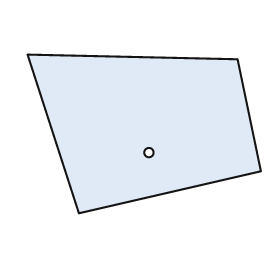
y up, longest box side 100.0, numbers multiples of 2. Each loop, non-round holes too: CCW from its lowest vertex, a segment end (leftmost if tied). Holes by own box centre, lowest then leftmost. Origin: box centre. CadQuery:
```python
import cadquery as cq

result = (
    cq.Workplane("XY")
    .moveTo(-28.0, -34.0)
    .lineTo(50.0, -16.0)
    .lineTo(40.0, 32.0)
    .lineTo(-50.0, 34.0)
    .close()
    .moveTo(2.0, -8.0)
    .circle(2.0)
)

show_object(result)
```